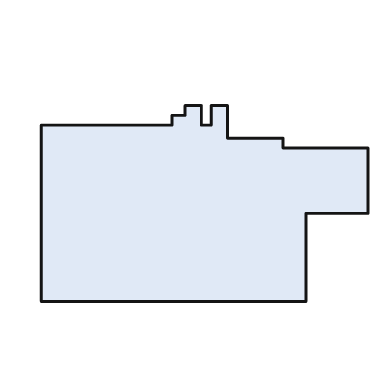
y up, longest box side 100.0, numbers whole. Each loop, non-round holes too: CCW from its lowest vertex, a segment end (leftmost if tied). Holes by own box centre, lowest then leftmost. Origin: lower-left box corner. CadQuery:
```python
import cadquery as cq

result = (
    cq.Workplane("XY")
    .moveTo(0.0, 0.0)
    .lineTo(81.0, 0.0)
    .lineTo(81.0, 27.0)
    .lineTo(100.0, 27.0)
    .lineTo(100.0, 47.0)
    .lineTo(74.0, 47.0)
    .lineTo(74.0, 50.0)
    .lineTo(57.0, 50.0)
    .lineTo(57.0, 60.0)
    .lineTo(52.0, 60.0)
    .lineTo(52.0, 54.0)
    .lineTo(49.0, 54.0)
    .lineTo(49.0, 60.0)
    .lineTo(44.0, 60.0)
    .lineTo(44.0, 57.0)
    .lineTo(40.0, 57.0)
    .lineTo(40.0, 54.0)
    .lineTo(0.0, 54.0)
    .close()
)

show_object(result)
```